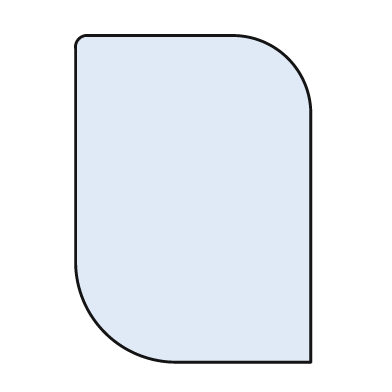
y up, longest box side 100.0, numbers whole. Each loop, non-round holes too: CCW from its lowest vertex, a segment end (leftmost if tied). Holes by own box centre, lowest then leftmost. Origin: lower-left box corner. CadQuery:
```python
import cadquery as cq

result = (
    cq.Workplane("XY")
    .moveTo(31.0, 0.0)
    .lineTo(72.0, 0.0)
    .lineTo(72.0, 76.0)
    .threePointArc((65.0, 93.0), (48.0, 100.0))
    .lineTo(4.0, 100.0)
    .threePointArc((1.0, 99.0), (0.0, 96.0))
    .lineTo(0.0, 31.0)
    .threePointArc((9.0, 9.0), (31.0, 0.0))
    .close()
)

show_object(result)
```